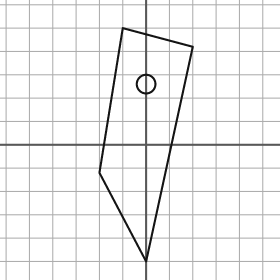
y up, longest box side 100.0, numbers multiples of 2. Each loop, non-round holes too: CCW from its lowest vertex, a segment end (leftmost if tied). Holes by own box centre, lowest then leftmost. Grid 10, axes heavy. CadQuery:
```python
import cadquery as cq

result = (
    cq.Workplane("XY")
    .moveTo(0.0, -50.0)
    .lineTo(20.0, 42.0)
    .lineTo(-10.0, 50.0)
    .lineTo(-20.0, -12.0)
    .close()
    .moveTo(0.0, 26.0)
    .circle(4.0)
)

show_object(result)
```